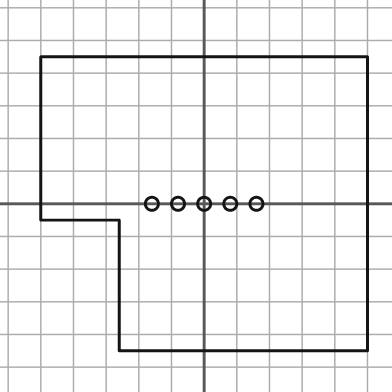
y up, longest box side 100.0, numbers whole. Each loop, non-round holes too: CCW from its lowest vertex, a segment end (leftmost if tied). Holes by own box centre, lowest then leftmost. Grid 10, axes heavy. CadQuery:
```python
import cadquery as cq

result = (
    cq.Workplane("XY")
    .moveTo(-26.0, -45.0)
    .lineTo(50.0, -45.0)
    .lineTo(50.0, 45.0)
    .lineTo(-50.0, 45.0)
    .lineTo(-50.0, -5.0)
    .lineTo(-26.0, -5.0)
    .close()
    .moveTo(-16.0, 0.0)
    .circle(2.0)
    .moveTo(-8.0, 0.0)
    .circle(2.0)
    .moveTo(0.0, 0.0)
    .circle(2.0)
    .moveTo(8.0, 0.0)
    .circle(2.0)
    .moveTo(16.0, 0.0)
    .circle(2.0)
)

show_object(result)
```